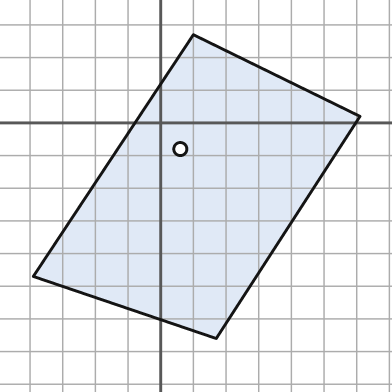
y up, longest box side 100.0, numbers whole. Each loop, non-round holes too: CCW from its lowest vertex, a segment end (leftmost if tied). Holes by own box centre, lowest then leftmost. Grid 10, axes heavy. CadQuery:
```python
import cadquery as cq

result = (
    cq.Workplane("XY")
    .moveTo(17.0, -66.0)
    .lineTo(61.0, 2.0)
    .lineTo(10.0, 27.0)
    .lineTo(-39.0, -47.0)
    .close()
    .moveTo(6.0, -8.0)
    .circle(2.0)
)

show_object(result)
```